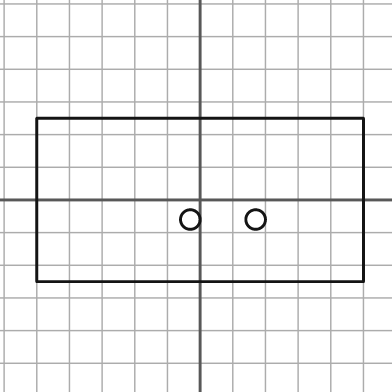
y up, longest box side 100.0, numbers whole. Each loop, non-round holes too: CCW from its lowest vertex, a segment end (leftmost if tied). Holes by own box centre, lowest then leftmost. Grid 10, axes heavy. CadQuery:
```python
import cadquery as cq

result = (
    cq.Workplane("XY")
    .moveTo(-50.0, -25.0)
    .lineTo(50.0, -25.0)
    .lineTo(50.0, 25.0)
    .lineTo(-50.0, 25.0)
    .close()
    .moveTo(-3.0, -6.0)
    .circle(3.0)
    .moveTo(17.0, -6.0)
    .circle(3.0)
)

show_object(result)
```